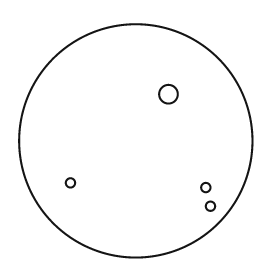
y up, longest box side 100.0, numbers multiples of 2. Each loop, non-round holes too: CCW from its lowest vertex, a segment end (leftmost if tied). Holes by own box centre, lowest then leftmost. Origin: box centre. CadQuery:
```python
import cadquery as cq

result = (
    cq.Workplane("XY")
    .moveTo(0.0, 0.0)
    .circle(50.0)
    .moveTo(32.0, -28.0)
    .circle(2.0)
    .moveTo(30.0, -20.0)
    .circle(2.0)
    .moveTo(-28.0, -18.0)
    .circle(2.0)
    .moveTo(14.0, 20.0)
    .circle(4.0)
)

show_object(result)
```